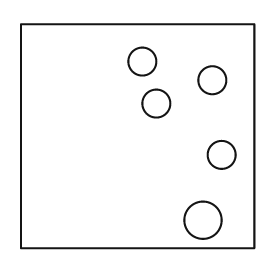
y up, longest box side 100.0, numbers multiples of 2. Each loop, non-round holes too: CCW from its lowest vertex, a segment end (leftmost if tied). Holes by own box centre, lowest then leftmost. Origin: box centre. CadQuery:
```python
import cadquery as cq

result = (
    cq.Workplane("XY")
    .moveTo(-50.0, -48.0)
    .lineTo(50.0, -48.0)
    .lineTo(50.0, 48.0)
    .lineTo(-50.0, 48.0)
    .close()
    .moveTo(28.0, -36.0)
    .circle(8.0)
    .moveTo(36.0, -8.0)
    .circle(6.0)
    .moveTo(8.0, 14.0)
    .circle(6.0)
    .moveTo(32.0, 24.0)
    .circle(6.0)
    .moveTo(2.0, 32.0)
    .circle(6.0)
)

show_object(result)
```